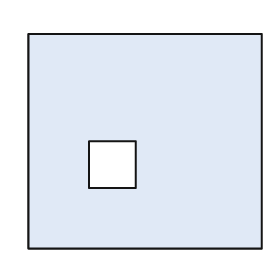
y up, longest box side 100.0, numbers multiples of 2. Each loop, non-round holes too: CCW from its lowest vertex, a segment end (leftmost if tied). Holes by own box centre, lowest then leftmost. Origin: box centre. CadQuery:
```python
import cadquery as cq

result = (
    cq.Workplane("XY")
    .moveTo(-50.0, -46.0)
    .lineTo(50.0, -46.0)
    .lineTo(50.0, 46.0)
    .lineTo(-50.0, 46.0)
    .close()
    .moveTo(-24.0, -20.0)
    .lineTo(-4.0, -20.0)
    .lineTo(-4.0, 0.0)
    .lineTo(-24.0, 0.0)
    .close()
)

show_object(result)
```